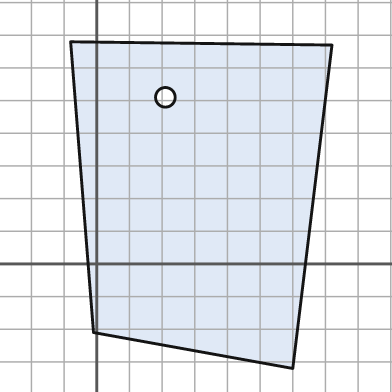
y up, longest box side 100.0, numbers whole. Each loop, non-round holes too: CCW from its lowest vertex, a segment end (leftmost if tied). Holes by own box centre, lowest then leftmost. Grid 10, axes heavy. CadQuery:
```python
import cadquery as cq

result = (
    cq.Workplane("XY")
    .moveTo(60.0, -32.0)
    .lineTo(72.0, 67.0)
    .lineTo(-8.0, 68.0)
    .lineTo(-1.0, -21.0)
    .close()
    .moveTo(21.0, 51.0)
    .circle(3.0)
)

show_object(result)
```